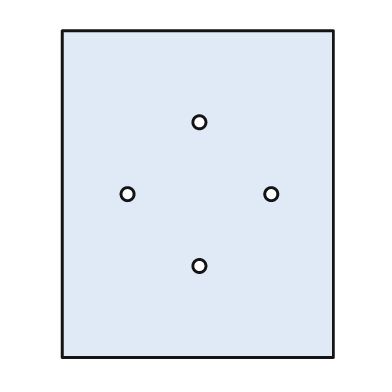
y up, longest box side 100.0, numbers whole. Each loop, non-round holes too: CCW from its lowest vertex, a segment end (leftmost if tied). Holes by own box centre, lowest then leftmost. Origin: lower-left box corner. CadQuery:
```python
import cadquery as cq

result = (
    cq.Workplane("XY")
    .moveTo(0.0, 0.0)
    .lineTo(83.0, 0.0)
    .lineTo(83.0, 100.0)
    .lineTo(0.0, 100.0)
    .close()
    .moveTo(42.0, 28.0)
    .circle(2.0)
    .moveTo(20.0, 50.0)
    .circle(2.0)
    .moveTo(64.0, 50.0)
    .circle(2.0)
    .moveTo(42.0, 72.0)
    .circle(2.0)
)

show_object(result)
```